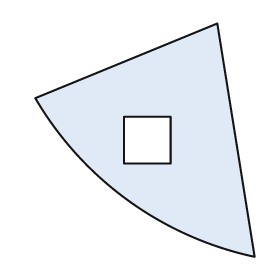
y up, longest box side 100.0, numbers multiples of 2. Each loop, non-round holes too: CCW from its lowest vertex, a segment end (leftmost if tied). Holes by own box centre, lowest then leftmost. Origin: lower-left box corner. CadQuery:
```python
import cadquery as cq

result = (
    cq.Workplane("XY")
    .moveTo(94.0, 0.0)
    .lineTo(78.0, 100.0)
    .lineTo(0.0, 68.0)
    .threePointArc((40.0, 24.0), (94.0, 0.0))
    .close()
    .moveTo(38.0, 40.0)
    .lineTo(58.0, 40.0)
    .lineTo(58.0, 60.0)
    .lineTo(38.0, 60.0)
    .close()
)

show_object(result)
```